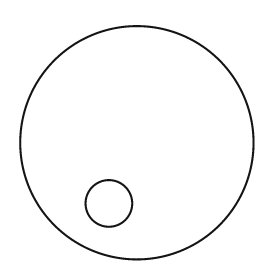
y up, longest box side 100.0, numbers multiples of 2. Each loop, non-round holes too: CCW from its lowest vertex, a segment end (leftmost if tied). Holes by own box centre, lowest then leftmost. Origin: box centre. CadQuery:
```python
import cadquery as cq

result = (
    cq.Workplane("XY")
    .moveTo(0.0, 0.0)
    .circle(50.0)
    .moveTo(-12.0, -26.0)
    .circle(10.0)
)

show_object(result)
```